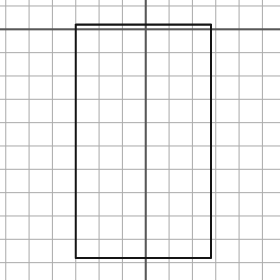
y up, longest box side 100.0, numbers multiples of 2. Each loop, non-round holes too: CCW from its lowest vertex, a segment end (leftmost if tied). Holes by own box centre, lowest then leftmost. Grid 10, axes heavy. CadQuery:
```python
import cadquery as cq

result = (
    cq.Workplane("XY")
    .moveTo(-30.0, -98.0)
    .lineTo(28.0, -98.0)
    .lineTo(28.0, 2.0)
    .lineTo(-30.0, 2.0)
    .close()
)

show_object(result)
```